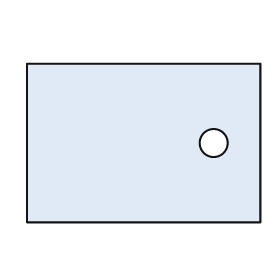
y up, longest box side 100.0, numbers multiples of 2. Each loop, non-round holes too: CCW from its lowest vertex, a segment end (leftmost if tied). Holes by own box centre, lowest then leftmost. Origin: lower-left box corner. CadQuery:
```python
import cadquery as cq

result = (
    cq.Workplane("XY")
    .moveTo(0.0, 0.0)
    .lineTo(100.0, 0.0)
    .lineTo(100.0, 68.0)
    .lineTo(0.0, 68.0)
    .close()
    .moveTo(80.0, 34.0)
    .circle(6.0)
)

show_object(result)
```